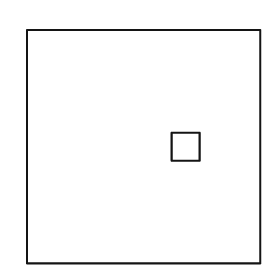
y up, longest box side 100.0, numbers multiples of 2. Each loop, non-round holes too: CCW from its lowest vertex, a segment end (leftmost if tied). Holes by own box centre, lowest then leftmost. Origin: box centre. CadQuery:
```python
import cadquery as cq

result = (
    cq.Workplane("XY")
    .moveTo(-50.0, -50.0)
    .lineTo(50.0, -50.0)
    .lineTo(50.0, 50.0)
    .lineTo(-50.0, 50.0)
    .close()
    .moveTo(12.0, -6.0)
    .lineTo(24.0, -6.0)
    .lineTo(24.0, 6.0)
    .lineTo(12.0, 6.0)
    .close()
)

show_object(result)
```